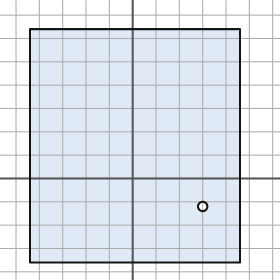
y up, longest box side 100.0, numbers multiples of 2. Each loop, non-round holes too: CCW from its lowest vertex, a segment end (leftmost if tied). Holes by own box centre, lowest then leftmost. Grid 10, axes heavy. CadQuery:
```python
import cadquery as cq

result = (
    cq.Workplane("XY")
    .moveTo(-44.0, -36.0)
    .lineTo(46.0, -36.0)
    .lineTo(46.0, 64.0)
    .lineTo(-44.0, 64.0)
    .close()
    .moveTo(30.0, -12.0)
    .circle(2.0)
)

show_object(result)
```